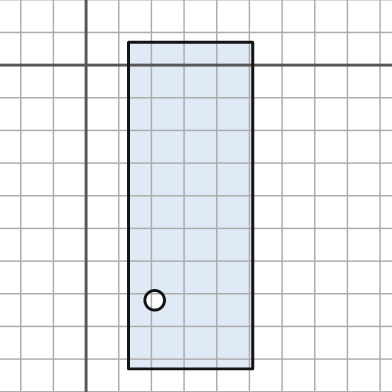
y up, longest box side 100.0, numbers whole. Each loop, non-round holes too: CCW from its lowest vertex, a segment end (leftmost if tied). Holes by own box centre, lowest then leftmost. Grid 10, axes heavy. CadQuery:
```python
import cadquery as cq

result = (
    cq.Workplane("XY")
    .moveTo(13.0, -93.0)
    .lineTo(51.0, -93.0)
    .lineTo(51.0, 7.0)
    .lineTo(13.0, 7.0)
    .close()
    .moveTo(21.0, -72.0)
    .circle(3.0)
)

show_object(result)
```